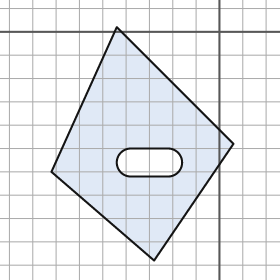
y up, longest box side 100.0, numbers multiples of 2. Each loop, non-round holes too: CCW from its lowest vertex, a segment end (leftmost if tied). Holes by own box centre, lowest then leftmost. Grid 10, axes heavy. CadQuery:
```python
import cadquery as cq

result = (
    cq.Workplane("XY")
    .moveTo(-28.0, -98.0)
    .lineTo(6.0, -48.0)
    .lineTo(-44.0, 2.0)
    .lineTo(-72.0, -60.0)
    .close()
    .moveTo(-38.0, -62.0)
    .lineTo(-22.0, -62.0)
    .threePointArc((-16.0, -56.0), (-22.0, -50.0))
    .lineTo(-38.0, -50.0)
    .threePointArc((-44.0, -56.0), (-38.0, -62.0))
    .close()
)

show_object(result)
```